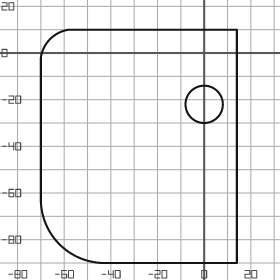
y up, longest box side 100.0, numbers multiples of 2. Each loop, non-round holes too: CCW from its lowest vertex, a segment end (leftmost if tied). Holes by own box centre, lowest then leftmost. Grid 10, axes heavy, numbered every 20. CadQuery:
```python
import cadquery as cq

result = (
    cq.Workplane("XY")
    .moveTo(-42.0, -90.0)
    .lineTo(14.0, -90.0)
    .lineTo(14.0, 10.0)
    .lineTo(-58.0, 10.0)
    .threePointArc((-66.0, 6.0), (-70.0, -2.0))
    .lineTo(-70.0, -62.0)
    .threePointArc((-62.0, -82.0), (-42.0, -90.0))
    .close()
    .moveTo(0.0, -22.0)
    .circle(8.0)
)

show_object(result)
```